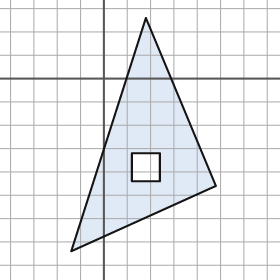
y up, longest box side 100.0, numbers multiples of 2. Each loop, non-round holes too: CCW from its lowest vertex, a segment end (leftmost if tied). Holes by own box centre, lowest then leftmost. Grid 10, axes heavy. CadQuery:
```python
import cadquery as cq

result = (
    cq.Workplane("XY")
    .moveTo(-14.0, -74.0)
    .lineTo(48.0, -46.0)
    .lineTo(18.0, 26.0)
    .close()
    .moveTo(12.0, -44.0)
    .lineTo(24.0, -44.0)
    .lineTo(24.0, -32.0)
    .lineTo(12.0, -32.0)
    .close()
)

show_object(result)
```